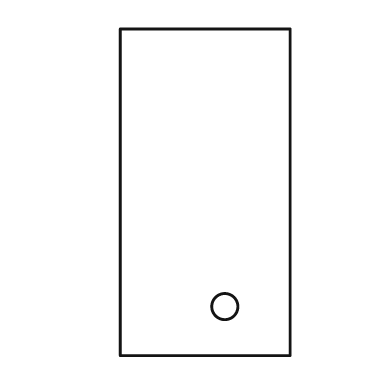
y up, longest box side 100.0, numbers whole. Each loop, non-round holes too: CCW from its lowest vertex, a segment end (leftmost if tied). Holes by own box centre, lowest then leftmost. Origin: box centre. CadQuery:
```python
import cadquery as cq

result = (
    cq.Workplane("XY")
    .moveTo(-26.0, -50.0)
    .lineTo(26.0, -50.0)
    .lineTo(26.0, 50.0)
    .lineTo(-26.0, 50.0)
    .close()
    .moveTo(6.0, -35.0)
    .circle(4.0)
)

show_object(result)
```